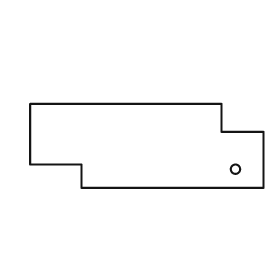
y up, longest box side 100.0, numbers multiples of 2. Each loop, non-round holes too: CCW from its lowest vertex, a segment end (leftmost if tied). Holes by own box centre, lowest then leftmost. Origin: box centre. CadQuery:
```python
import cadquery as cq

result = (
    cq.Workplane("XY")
    .moveTo(-28.0, -18.0)
    .lineTo(50.0, -18.0)
    .lineTo(50.0, 6.0)
    .lineTo(32.0, 6.0)
    .lineTo(32.0, 18.0)
    .lineTo(-50.0, 18.0)
    .lineTo(-50.0, -8.0)
    .lineTo(-28.0, -8.0)
    .close()
    .moveTo(38.0, -10.0)
    .circle(2.0)
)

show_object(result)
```